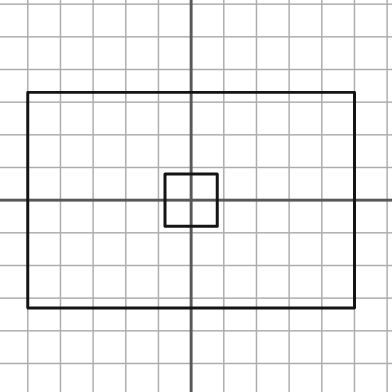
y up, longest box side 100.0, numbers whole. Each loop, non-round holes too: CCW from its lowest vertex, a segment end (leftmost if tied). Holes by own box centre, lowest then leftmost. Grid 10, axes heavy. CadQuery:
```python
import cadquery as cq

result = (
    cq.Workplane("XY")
    .moveTo(-50.0, -33.0)
    .lineTo(50.0, -33.0)
    .lineTo(50.0, 33.0)
    .lineTo(-50.0, 33.0)
    .close()
    .moveTo(-8.0, -8.0)
    .lineTo(8.0, -8.0)
    .lineTo(8.0, 8.0)
    .lineTo(-8.0, 8.0)
    .close()
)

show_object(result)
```